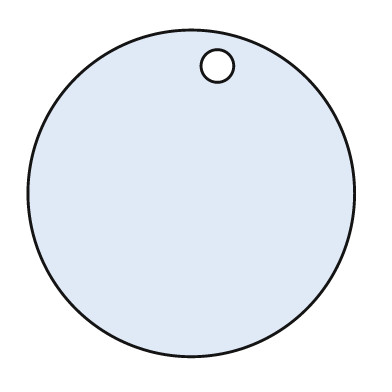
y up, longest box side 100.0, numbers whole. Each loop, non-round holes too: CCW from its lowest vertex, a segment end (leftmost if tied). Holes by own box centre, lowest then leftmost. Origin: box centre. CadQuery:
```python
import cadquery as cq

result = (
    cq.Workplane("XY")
    .moveTo(0.0, 0.0)
    .circle(50.0)
    .moveTo(8.0, 39.0)
    .circle(5.0)
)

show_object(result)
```